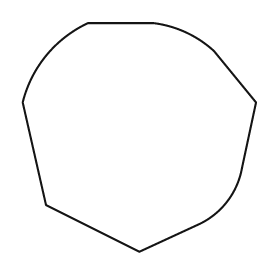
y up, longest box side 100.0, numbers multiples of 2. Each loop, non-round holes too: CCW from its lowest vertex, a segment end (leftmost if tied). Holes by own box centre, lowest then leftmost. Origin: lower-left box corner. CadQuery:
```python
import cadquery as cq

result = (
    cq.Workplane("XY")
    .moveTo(50.0, 0.0)
    .lineTo(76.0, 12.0)
    .threePointArc((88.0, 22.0), (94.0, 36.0))
    .lineTo(100.0, 64.0)
    .lineTo(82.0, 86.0)
    .threePointArc((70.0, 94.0), (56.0, 98.0))
    .lineTo(28.0, 98.0)
    .threePointArc((10.0, 84.0), (0.0, 64.0))
    .lineTo(10.0, 20.0)
    .close()
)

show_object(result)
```